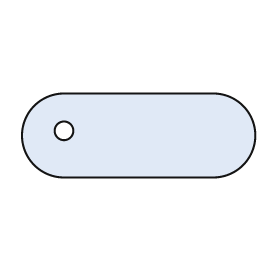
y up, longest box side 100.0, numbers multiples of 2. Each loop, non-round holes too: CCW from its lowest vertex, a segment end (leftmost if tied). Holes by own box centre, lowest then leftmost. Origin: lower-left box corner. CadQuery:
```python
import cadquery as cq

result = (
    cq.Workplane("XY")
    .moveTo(18.0, 0.0)
    .lineTo(82.0, 0.0)
    .threePointArc((100.0, 18.0), (82.0, 36.0))
    .lineTo(18.0, 36.0)
    .threePointArc((0.0, 18.0), (18.0, 0.0))
    .close()
    .moveTo(18.0, 20.0)
    .circle(4.0)
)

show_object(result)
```